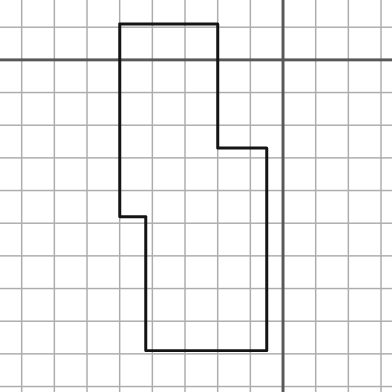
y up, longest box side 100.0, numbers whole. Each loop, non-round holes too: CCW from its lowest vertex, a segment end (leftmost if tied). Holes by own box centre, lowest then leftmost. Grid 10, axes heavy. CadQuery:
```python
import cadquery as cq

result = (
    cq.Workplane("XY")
    .moveTo(-42.0, -89.0)
    .lineTo(-5.0, -89.0)
    .lineTo(-5.0, -27.0)
    .lineTo(-20.0, -27.0)
    .lineTo(-20.0, 11.0)
    .lineTo(-50.0, 11.0)
    .lineTo(-50.0, -48.0)
    .lineTo(-42.0, -48.0)
    .close()
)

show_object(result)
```